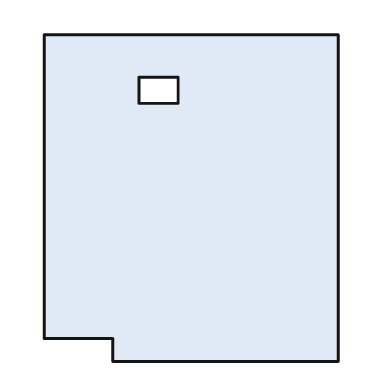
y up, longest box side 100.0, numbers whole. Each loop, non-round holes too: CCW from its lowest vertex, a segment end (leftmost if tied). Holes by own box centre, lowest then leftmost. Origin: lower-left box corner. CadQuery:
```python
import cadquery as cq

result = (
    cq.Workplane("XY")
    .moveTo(21.0, 0.0)
    .lineTo(90.0, 0.0)
    .lineTo(90.0, 100.0)
    .lineTo(0.0, 100.0)
    .lineTo(0.0, 7.0)
    .lineTo(21.0, 7.0)
    .close()
    .moveTo(29.0, 79.0)
    .lineTo(41.0, 79.0)
    .lineTo(41.0, 87.0)
    .lineTo(29.0, 87.0)
    .close()
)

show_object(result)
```